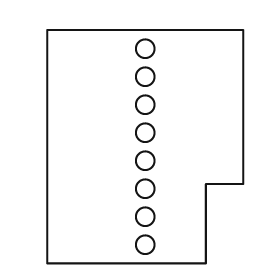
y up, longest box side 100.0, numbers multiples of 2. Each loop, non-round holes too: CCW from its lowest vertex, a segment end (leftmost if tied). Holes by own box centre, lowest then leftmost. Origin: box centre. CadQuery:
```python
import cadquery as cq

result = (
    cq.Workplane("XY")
    .moveTo(-42.0, -50.0)
    .lineTo(26.0, -50.0)
    .lineTo(26.0, -16.0)
    .lineTo(42.0, -16.0)
    .lineTo(42.0, 50.0)
    .lineTo(-42.0, 50.0)
    .close()
    .moveTo(0.0, -42.0)
    .circle(4.0)
    .moveTo(0.0, -30.0)
    .circle(4.0)
    .moveTo(0.0, -18.0)
    .circle(4.0)
    .moveTo(0.0, -6.0)
    .circle(4.0)
    .moveTo(0.0, 6.0)
    .circle(4.0)
    .moveTo(0.0, 18.0)
    .circle(4.0)
    .moveTo(0.0, 30.0)
    .circle(4.0)
    .moveTo(0.0, 42.0)
    .circle(4.0)
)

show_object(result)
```